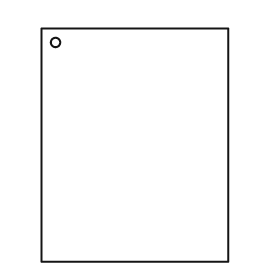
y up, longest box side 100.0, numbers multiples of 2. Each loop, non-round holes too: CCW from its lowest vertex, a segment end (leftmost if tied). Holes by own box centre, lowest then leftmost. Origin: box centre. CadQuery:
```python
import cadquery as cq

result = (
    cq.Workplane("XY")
    .moveTo(-40.0, -50.0)
    .lineTo(40.0, -50.0)
    .lineTo(40.0, 50.0)
    .lineTo(-40.0, 50.0)
    .close()
    .moveTo(-34.0, 44.0)
    .circle(2.0)
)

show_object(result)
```